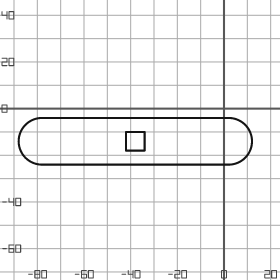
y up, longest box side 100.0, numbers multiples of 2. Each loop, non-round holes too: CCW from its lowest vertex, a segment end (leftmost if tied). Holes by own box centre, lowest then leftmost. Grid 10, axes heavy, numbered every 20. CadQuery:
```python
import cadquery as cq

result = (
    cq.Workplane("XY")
    .moveTo(-78.0, -24.0)
    .lineTo(2.0, -24.0)
    .threePointArc((12.0, -14.0), (2.0, -4.0))
    .lineTo(-78.0, -4.0)
    .threePointArc((-88.0, -14.0), (-78.0, -24.0))
    .close()
    .moveTo(-42.0, -18.0)
    .lineTo(-34.0, -18.0)
    .lineTo(-34.0, -10.0)
    .lineTo(-42.0, -10.0)
    .close()
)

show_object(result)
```